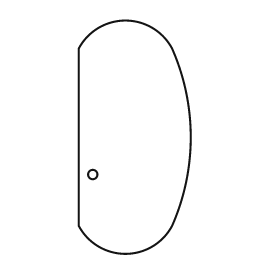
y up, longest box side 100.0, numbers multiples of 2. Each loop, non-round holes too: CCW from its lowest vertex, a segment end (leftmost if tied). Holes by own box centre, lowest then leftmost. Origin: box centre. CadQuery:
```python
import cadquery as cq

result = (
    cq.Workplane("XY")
    .moveTo(-24.0, -38.0)
    .threePointArc((-4.0, -50.0), (16.0, -38.0))
    .threePointArc((24.0, 0.0), (16.0, 38.0))
    .threePointArc((-4.0, 50.0), (-24.0, 38.0))
    .close()
    .moveTo(-18.0, -16.0)
    .circle(2.0)
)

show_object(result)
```